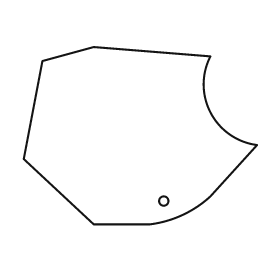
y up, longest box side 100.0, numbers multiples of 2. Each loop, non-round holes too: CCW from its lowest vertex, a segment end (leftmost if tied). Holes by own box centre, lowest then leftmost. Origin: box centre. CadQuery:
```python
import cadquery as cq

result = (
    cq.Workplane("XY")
    .moveTo(-20.0, -38.0)
    .lineTo(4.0, -38.0)
    .threePointArc((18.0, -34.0), (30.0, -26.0))
    .lineTo(50.0, -4.0)
    .threePointArc((30.0, 10.0), (30.0, 34.0))
    .lineTo(-20.0, 38.0)
    .lineTo(-42.0, 32.0)
    .lineTo(-50.0, -10.0)
    .close()
    .moveTo(10.0, -28.0)
    .circle(2.0)
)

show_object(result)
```